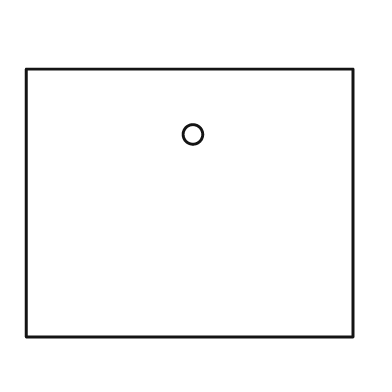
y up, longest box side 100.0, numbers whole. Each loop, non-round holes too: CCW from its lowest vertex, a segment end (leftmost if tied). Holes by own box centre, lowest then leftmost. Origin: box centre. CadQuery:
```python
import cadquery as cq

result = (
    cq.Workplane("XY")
    .moveTo(-50.0, -41.0)
    .lineTo(50.0, -41.0)
    .lineTo(50.0, 41.0)
    .lineTo(-50.0, 41.0)
    .close()
    .moveTo(1.0, 21.0)
    .circle(3.0)
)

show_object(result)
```